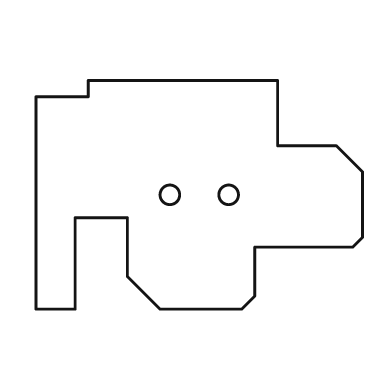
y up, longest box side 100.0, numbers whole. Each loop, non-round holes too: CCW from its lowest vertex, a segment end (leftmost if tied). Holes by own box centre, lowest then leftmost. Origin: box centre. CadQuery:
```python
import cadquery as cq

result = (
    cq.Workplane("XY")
    .moveTo(-50.0, -35.0)
    .lineTo(-38.0, -35.0)
    .lineTo(-38.0, -7.0)
    .lineTo(-22.0, -7.0)
    .lineTo(-22.0, -25.0)
    .lineTo(-12.0, -35.0)
    .lineTo(13.0, -35.0)
    .lineTo(17.0, -31.0)
    .lineTo(17.0, -16.0)
    .lineTo(47.0, -16.0)
    .lineTo(50.0, -13.0)
    .lineTo(50.0, 7.0)
    .lineTo(42.0, 15.0)
    .lineTo(24.0, 15.0)
    .lineTo(24.0, 35.0)
    .lineTo(-34.0, 35.0)
    .lineTo(-34.0, 30.0)
    .lineTo(-50.0, 30.0)
    .close()
    .moveTo(-9.0, 0.0)
    .circle(3.0)
    .moveTo(9.0, 0.0)
    .circle(3.0)
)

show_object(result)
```